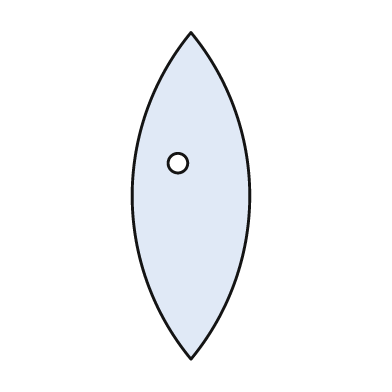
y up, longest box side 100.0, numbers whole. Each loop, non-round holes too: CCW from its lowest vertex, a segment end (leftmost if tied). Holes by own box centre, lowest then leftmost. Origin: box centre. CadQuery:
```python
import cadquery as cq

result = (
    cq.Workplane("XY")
    .moveTo(0.0, -50.0)
    .threePointArc((18.0, 0.0), (0.0, 50.0))
    .threePointArc((-18.0, 0.0), (0.0, -50.0))
    .close()
    .moveTo(-4.0, 10.0)
    .circle(3.0)
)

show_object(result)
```